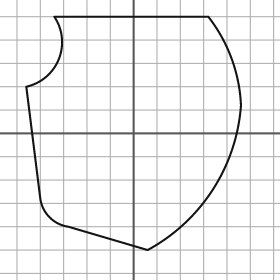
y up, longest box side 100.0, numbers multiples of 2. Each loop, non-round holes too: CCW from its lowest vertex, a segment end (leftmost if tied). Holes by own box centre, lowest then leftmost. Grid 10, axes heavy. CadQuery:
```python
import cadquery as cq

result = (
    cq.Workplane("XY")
    .moveTo(6.0, -50.0)
    .threePointArc((34.0, -24.0), (46.0, 12.0))
    .threePointArc((42.0, 32.0), (32.0, 50.0))
    .lineTo(-34.0, 50.0)
    .threePointArc((-32.0, 32.0), (-46.0, 20.0))
    .lineTo(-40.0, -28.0)
    .threePointArc((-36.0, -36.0), (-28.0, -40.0))
    .close()
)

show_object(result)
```